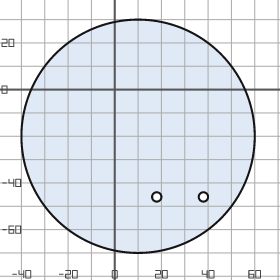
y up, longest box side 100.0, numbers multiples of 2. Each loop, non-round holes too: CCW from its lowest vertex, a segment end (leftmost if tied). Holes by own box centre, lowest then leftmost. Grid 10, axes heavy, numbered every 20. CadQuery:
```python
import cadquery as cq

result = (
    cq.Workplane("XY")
    .moveTo(10.0, -20.0)
    .circle(50.0)
    .moveTo(18.0, -46.0)
    .circle(2.0)
    .moveTo(38.0, -46.0)
    .circle(2.0)
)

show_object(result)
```